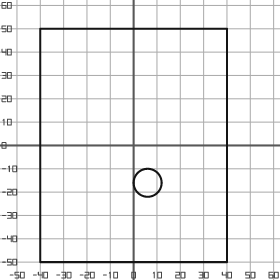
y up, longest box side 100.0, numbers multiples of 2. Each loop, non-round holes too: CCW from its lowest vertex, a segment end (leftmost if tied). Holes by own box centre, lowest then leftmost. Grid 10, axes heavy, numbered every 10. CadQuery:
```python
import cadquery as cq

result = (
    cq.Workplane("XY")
    .moveTo(-40.0, -50.0)
    .lineTo(40.0, -50.0)
    .lineTo(40.0, 50.0)
    .lineTo(-40.0, 50.0)
    .close()
    .moveTo(6.0, -16.0)
    .circle(6.0)
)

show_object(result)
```